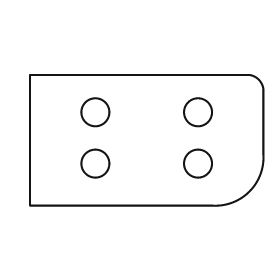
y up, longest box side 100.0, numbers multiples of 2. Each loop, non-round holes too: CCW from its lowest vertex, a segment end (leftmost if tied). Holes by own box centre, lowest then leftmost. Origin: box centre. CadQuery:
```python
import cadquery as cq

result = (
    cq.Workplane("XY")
    .moveTo(-50.0, -28.0)
    .lineTo(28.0, -28.0)
    .threePointArc((44.0, -22.0), (50.0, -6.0))
    .lineTo(50.0, 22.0)
    .threePointArc((48.0, 26.0), (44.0, 28.0))
    .lineTo(-50.0, 28.0)
    .close()
    .moveTo(-22.0, -10.0)
    .circle(6.0)
    .moveTo(22.0, -10.0)
    .circle(6.0)
    .moveTo(-22.0, 12.0)
    .circle(6.0)
    .moveTo(22.0, 12.0)
    .circle(6.0)
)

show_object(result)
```